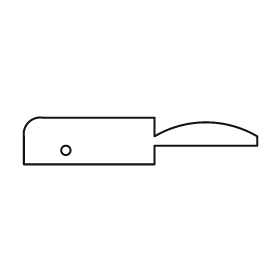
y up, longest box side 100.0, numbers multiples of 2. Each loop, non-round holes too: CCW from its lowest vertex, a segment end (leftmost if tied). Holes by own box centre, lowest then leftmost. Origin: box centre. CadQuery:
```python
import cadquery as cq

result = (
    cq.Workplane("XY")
    .moveTo(-50.0, -10.0)
    .lineTo(6.0, -10.0)
    .lineTo(6.0, -2.0)
    .lineTo(50.0, -2.0)
    .lineTo(50.0, 2.0)
    .threePointArc((28.0, 8.0), (6.0, 2.0))
    .lineTo(6.0, 10.0)
    .lineTo(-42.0, 10.0)
    .threePointArc((-48.0, 8.0), (-50.0, 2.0))
    .close()
    .moveTo(-32.0, -4.0)
    .circle(2.0)
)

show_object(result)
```